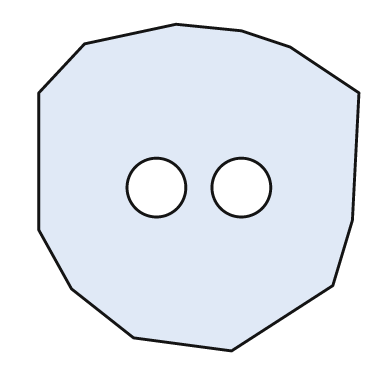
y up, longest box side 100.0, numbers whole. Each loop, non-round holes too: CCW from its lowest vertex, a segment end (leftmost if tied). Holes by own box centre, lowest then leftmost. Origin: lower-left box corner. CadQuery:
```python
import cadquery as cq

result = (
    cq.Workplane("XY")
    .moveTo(59.0, 0.0)
    .lineTo(90.0, 20.0)
    .lineTo(96.0, 40.0)
    .lineTo(98.0, 79.0)
    .lineTo(77.0, 93.0)
    .lineTo(62.0, 98.0)
    .lineTo(42.0, 100.0)
    .lineTo(14.0, 94.0)
    .lineTo(0.0, 79.0)
    .lineTo(0.0, 37.0)
    .lineTo(10.0, 19.0)
    .lineTo(29.0, 4.0)
    .close()
    .moveTo(36.0, 50.0)
    .circle(9.0)
    .moveTo(62.0, 50.0)
    .circle(9.0)
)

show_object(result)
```